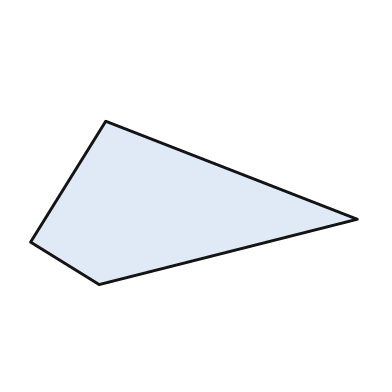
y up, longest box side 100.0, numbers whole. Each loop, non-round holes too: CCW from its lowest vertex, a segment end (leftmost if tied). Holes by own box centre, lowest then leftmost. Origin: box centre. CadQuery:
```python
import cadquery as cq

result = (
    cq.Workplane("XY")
    .moveTo(-29.0, -25.0)
    .lineTo(50.0, -5.0)
    .lineTo(-27.0, 25.0)
    .lineTo(-50.0, -12.0)
    .close()
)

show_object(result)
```